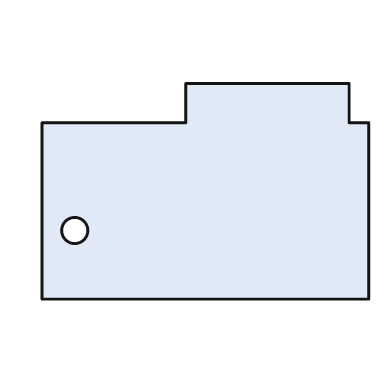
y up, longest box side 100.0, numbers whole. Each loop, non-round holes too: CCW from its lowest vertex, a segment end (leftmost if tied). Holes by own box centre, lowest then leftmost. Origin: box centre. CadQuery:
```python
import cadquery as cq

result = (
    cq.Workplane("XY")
    .moveTo(-50.0, -33.0)
    .lineTo(50.0, -33.0)
    .lineTo(50.0, 21.0)
    .lineTo(44.0, 21.0)
    .lineTo(44.0, 33.0)
    .lineTo(-6.0, 33.0)
    .lineTo(-6.0, 21.0)
    .lineTo(-50.0, 21.0)
    .close()
    .moveTo(-40.0, -12.0)
    .circle(4.0)
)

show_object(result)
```